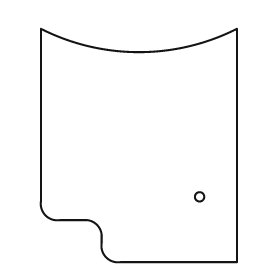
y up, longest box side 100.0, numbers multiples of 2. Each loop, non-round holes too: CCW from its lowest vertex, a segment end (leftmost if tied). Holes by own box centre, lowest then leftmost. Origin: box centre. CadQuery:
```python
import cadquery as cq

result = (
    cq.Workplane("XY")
    .moveTo(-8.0, -50.0)
    .lineTo(42.0, -50.0)
    .lineTo(42.0, 50.0)
    .threePointArc((0.0, 40.0), (-42.0, 50.0))
    .lineTo(-42.0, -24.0)
    .threePointArc((-40.0, -30.0), (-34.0, -32.0))
    .lineTo(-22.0, -32.0)
    .threePointArc((-18.0, -34.0), (-16.0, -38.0))
    .lineTo(-16.0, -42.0)
    .threePointArc((-14.0, -48.0), (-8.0, -50.0))
    .close()
    .moveTo(26.0, -22.0)
    .circle(2.0)
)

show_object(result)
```